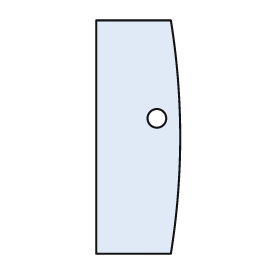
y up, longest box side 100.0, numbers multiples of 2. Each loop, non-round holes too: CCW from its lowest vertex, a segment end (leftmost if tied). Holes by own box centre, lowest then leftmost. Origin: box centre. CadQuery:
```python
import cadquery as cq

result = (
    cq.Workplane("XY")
    .moveTo(-18.0, -50.0)
    .lineTo(14.0, -50.0)
    .threePointArc((18.0, 0.0), (14.0, 50.0))
    .lineTo(-18.0, 50.0)
    .close()
    .moveTo(8.0, 8.0)
    .circle(4.0)
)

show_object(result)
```